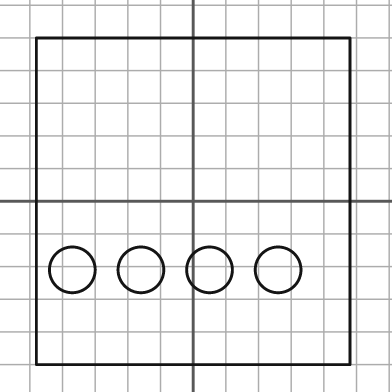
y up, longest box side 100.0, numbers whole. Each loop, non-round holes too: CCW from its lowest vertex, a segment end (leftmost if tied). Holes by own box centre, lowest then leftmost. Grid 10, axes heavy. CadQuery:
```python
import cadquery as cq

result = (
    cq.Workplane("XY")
    .moveTo(-48.0, -50.0)
    .lineTo(48.0, -50.0)
    .lineTo(48.0, 50.0)
    .lineTo(-48.0, 50.0)
    .close()
    .moveTo(-37.0, -21.0)
    .circle(7.0)
    .moveTo(-16.0, -21.0)
    .circle(7.0)
    .moveTo(5.0, -21.0)
    .circle(7.0)
    .moveTo(26.0, -21.0)
    .circle(7.0)
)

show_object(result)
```